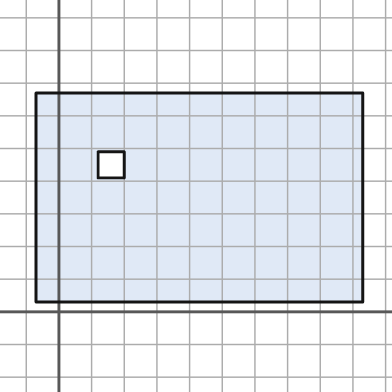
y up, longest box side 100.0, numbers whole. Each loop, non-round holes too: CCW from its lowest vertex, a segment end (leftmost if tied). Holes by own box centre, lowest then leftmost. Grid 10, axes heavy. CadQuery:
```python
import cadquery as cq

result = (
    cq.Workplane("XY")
    .moveTo(-7.0, 3.0)
    .lineTo(93.0, 3.0)
    .lineTo(93.0, 67.0)
    .lineTo(-7.0, 67.0)
    .close()
    .moveTo(12.0, 41.0)
    .lineTo(20.0, 41.0)
    .lineTo(20.0, 49.0)
    .lineTo(12.0, 49.0)
    .close()
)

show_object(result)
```